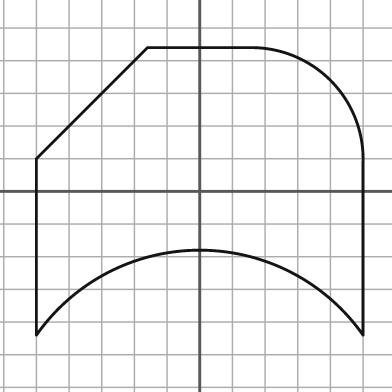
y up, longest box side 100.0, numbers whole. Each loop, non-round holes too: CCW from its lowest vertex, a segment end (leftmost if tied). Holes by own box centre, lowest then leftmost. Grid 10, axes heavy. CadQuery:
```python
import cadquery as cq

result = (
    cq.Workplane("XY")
    .moveTo(-50.0, -44.0)
    .threePointArc((0.0, -18.0), (50.0, -44.0))
    .lineTo(50.0, 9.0)
    .threePointArc((40.0, 34.0), (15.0, 44.0))
    .lineTo(-16.0, 44.0)
    .lineTo(-50.0, 10.0)
    .close()
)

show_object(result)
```